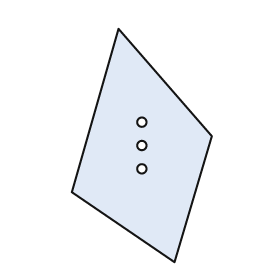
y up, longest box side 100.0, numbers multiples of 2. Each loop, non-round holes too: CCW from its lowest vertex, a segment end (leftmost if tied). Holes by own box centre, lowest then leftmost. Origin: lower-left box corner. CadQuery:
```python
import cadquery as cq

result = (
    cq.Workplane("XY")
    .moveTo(44.0, 0.0)
    .lineTo(60.0, 54.0)
    .lineTo(20.0, 100.0)
    .lineTo(0.0, 30.0)
    .close()
    .moveTo(30.0, 40.0)
    .circle(2.0)
    .moveTo(30.0, 50.0)
    .circle(2.0)
    .moveTo(30.0, 60.0)
    .circle(2.0)
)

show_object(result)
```